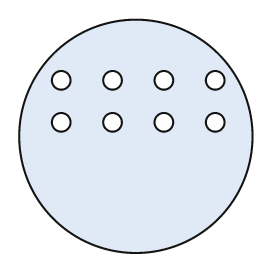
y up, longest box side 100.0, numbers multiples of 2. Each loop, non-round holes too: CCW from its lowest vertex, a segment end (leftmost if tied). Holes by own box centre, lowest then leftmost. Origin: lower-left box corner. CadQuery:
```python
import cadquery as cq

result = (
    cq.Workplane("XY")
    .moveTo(50.0, 50.0)
    .circle(50.0)
    .moveTo(18.0, 56.0)
    .circle(4.0)
    .moveTo(40.0, 56.0)
    .circle(4.0)
    .moveTo(62.0, 56.0)
    .circle(4.0)
    .moveTo(84.0, 56.0)
    .circle(4.0)
    .moveTo(18.0, 74.0)
    .circle(4.0)
    .moveTo(40.0, 74.0)
    .circle(4.0)
    .moveTo(62.0, 74.0)
    .circle(4.0)
    .moveTo(84.0, 74.0)
    .circle(4.0)
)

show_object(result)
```